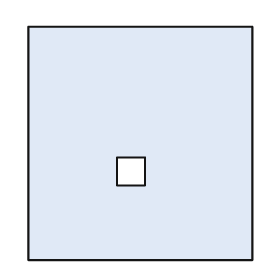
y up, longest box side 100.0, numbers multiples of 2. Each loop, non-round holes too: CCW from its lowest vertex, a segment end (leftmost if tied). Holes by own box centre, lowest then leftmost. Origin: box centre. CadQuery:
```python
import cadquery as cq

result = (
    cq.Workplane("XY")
    .moveTo(-48.0, -50.0)
    .lineTo(48.0, -50.0)
    .lineTo(48.0, 50.0)
    .lineTo(-48.0, 50.0)
    .close()
    .moveTo(-10.0, -18.0)
    .lineTo(2.0, -18.0)
    .lineTo(2.0, -6.0)
    .lineTo(-10.0, -6.0)
    .close()
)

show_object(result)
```